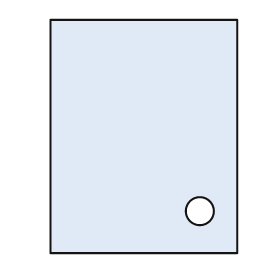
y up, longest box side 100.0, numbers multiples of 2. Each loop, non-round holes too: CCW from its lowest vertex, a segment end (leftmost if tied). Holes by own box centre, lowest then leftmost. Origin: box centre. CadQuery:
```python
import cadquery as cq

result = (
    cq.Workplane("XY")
    .moveTo(-40.0, -50.0)
    .lineTo(40.0, -50.0)
    .lineTo(40.0, 50.0)
    .lineTo(-40.0, 50.0)
    .close()
    .moveTo(24.0, -32.0)
    .circle(6.0)
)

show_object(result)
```